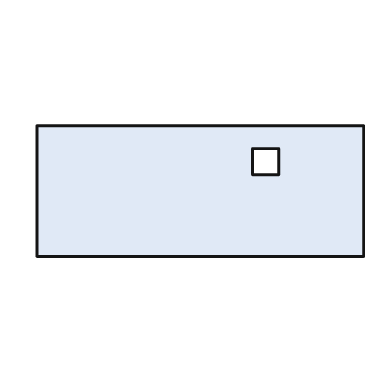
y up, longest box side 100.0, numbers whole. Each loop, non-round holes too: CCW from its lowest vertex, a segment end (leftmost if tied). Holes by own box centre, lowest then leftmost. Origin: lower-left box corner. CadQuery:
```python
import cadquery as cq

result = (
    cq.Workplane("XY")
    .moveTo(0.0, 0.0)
    .lineTo(100.0, 0.0)
    .lineTo(100.0, 40.0)
    .lineTo(0.0, 40.0)
    .close()
    .moveTo(66.0, 25.0)
    .lineTo(74.0, 25.0)
    .lineTo(74.0, 33.0)
    .lineTo(66.0, 33.0)
    .close()
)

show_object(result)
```